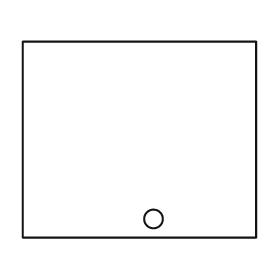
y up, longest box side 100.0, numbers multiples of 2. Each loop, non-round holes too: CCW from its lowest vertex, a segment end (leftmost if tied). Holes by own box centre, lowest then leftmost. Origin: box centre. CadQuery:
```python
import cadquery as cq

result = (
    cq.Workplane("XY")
    .moveTo(-50.0, -42.0)
    .lineTo(50.0, -42.0)
    .lineTo(50.0, 42.0)
    .lineTo(-50.0, 42.0)
    .close()
    .moveTo(6.0, -34.0)
    .circle(4.0)
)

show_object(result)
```